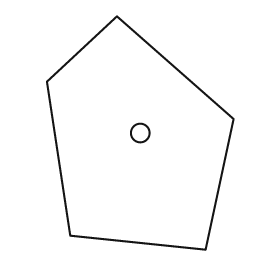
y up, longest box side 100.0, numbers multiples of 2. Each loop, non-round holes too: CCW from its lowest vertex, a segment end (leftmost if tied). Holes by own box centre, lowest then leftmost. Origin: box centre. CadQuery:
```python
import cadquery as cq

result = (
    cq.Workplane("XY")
    .moveTo(28.0, -50.0)
    .lineTo(40.0, 6.0)
    .lineTo(-10.0, 50.0)
    .lineTo(-40.0, 22.0)
    .lineTo(-30.0, -44.0)
    .close()
    .moveTo(0.0, 0.0)
    .circle(4.0)
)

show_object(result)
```